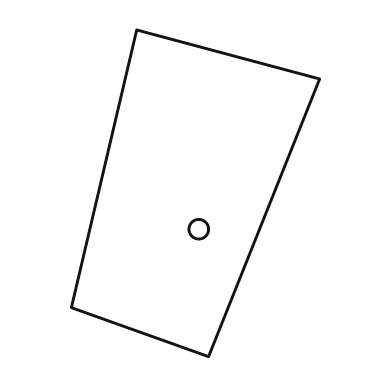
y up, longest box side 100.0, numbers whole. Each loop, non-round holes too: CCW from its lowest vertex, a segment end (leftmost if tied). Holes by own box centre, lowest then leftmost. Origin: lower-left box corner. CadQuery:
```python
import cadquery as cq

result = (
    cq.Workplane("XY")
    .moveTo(42.0, 0.0)
    .lineTo(76.0, 85.0)
    .lineTo(20.0, 100.0)
    .lineTo(0.0, 15.0)
    .close()
    .moveTo(39.0, 39.0)
    .circle(3.0)
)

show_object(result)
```